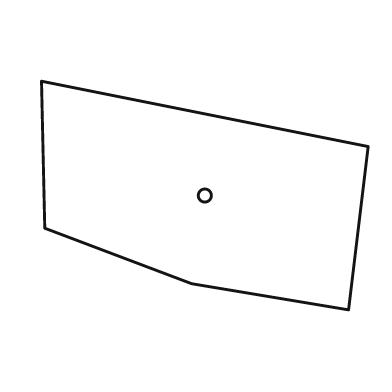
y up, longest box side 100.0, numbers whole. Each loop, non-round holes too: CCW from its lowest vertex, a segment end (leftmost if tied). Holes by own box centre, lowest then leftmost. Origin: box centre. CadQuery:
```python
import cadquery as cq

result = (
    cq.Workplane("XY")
    .moveTo(44.0, -35.0)
    .lineTo(50.0, 15.0)
    .lineTo(-50.0, 35.0)
    .lineTo(-49.0, -10.0)
    .lineTo(-4.0, -27.0)
    .close()
    .moveTo(0.0, 0.0)
    .circle(2.0)
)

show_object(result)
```